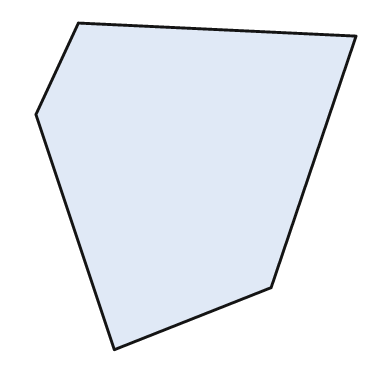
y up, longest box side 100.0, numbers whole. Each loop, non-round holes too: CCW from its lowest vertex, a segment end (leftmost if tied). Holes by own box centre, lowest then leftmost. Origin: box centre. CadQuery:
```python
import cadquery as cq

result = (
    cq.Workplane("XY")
    .moveTo(-25.0, -50.0)
    .lineTo(23.0, -31.0)
    .lineTo(49.0, 46.0)
    .lineTo(-36.0, 50.0)
    .lineTo(-49.0, 22.0)
    .close()
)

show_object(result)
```